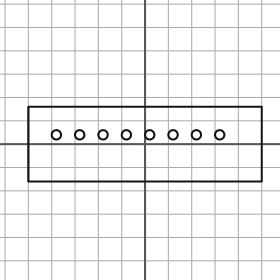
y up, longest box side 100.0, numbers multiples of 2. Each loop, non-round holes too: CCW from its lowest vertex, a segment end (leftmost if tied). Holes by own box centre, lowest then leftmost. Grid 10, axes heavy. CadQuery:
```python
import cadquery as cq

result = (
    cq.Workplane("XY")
    .moveTo(-50.0, -16.0)
    .lineTo(50.0, -16.0)
    .lineTo(50.0, 16.0)
    .lineTo(-50.0, 16.0)
    .close()
    .moveTo(-38.0, 4.0)
    .circle(2.0)
    .moveTo(-28.0, 4.0)
    .circle(2.0)
    .moveTo(-18.0, 4.0)
    .circle(2.0)
    .moveTo(-8.0, 4.0)
    .circle(2.0)
    .moveTo(2.0, 4.0)
    .circle(2.0)
    .moveTo(12.0, 4.0)
    .circle(2.0)
    .moveTo(22.0, 4.0)
    .circle(2.0)
    .moveTo(32.0, 4.0)
    .circle(2.0)
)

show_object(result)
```